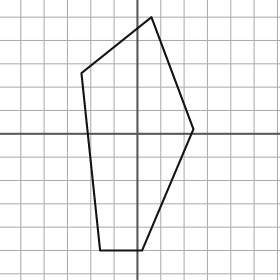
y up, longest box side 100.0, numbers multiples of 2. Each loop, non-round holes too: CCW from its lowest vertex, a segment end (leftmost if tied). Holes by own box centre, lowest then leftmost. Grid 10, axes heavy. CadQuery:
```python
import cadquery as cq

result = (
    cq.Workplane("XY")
    .moveTo(-16.0, -50.0)
    .lineTo(2.0, -50.0)
    .lineTo(24.0, 2.0)
    .lineTo(6.0, 50.0)
    .lineTo(-24.0, 26.0)
    .close()
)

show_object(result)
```